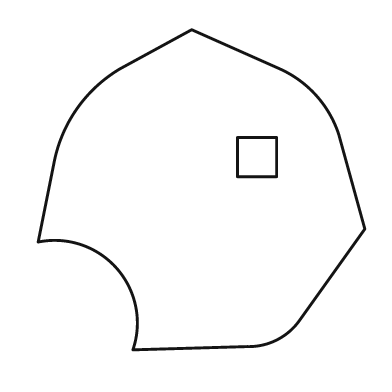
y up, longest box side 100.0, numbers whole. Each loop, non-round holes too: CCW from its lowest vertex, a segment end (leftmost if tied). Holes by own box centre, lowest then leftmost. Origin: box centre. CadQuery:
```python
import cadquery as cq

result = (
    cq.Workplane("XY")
    .moveTo(-21.0, -49.0)
    .lineTo(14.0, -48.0)
    .threePointArc((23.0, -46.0), (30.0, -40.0))
    .lineTo(50.0, -12.0)
    .lineTo(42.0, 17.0)
    .threePointArc((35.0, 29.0), (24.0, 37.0))
    .lineTo(-3.0, 49.0)
    .lineTo(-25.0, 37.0)
    .threePointArc((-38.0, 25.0), (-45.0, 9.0))
    .lineTo(-50.0, -16.0)
    .threePointArc((-26.0, -24.0), (-21.0, -49.0))
    .close()
    .moveTo(11.0, 4.0)
    .lineTo(23.0, 4.0)
    .lineTo(23.0, 16.0)
    .lineTo(11.0, 16.0)
    .close()
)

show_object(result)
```